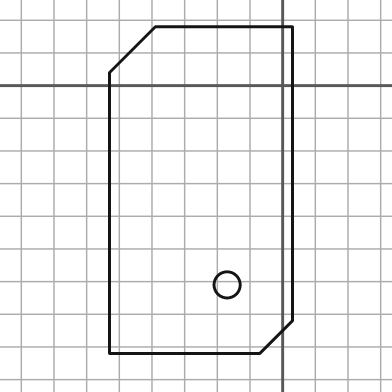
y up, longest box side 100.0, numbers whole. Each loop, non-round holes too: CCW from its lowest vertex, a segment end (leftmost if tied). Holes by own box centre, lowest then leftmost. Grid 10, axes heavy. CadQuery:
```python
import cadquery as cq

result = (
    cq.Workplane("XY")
    .moveTo(-53.0, -82.0)
    .lineTo(-7.0, -82.0)
    .lineTo(3.0, -72.0)
    .lineTo(3.0, 18.0)
    .lineTo(-39.0, 18.0)
    .lineTo(-53.0, 4.0)
    .close()
    .moveTo(-17.0, -61.0)
    .circle(4.0)
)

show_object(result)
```